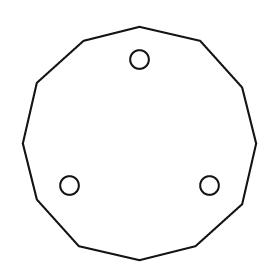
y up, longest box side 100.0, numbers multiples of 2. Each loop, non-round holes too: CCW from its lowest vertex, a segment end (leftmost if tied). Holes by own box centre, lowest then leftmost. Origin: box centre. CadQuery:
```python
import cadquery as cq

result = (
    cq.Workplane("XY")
    .moveTo(0.0, -50.0)
    .lineTo(24.0, -44.0)
    .lineTo(44.0, -26.0)
    .lineTo(50.0, 0.0)
    .lineTo(44.0, 24.0)
    .lineTo(26.0, 44.0)
    .lineTo(0.0, 50.0)
    .lineTo(-24.0, 44.0)
    .lineTo(-44.0, 26.0)
    .lineTo(-50.0, 0.0)
    .lineTo(-44.0, -24.0)
    .lineTo(-26.0, -44.0)
    .close()
    .moveTo(-30.0, -18.0)
    .circle(4.0)
    .moveTo(30.0, -18.0)
    .circle(4.0)
    .moveTo(0.0, 36.0)
    .circle(4.0)
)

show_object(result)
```